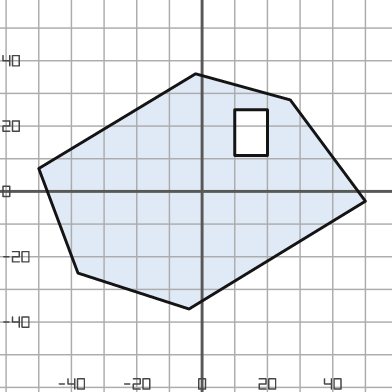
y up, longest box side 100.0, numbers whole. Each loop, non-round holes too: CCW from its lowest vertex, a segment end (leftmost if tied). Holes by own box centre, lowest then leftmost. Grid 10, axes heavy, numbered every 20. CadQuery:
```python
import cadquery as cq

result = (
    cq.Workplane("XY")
    .moveTo(-4.0, -36.0)
    .lineTo(50.0, -3.0)
    .lineTo(27.0, 28.0)
    .lineTo(-2.0, 36.0)
    .lineTo(-50.0, 7.0)
    .lineTo(-38.0, -25.0)
    .close()
    .moveTo(10.0, 11.0)
    .lineTo(20.0, 11.0)
    .lineTo(20.0, 25.0)
    .lineTo(10.0, 25.0)
    .close()
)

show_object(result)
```